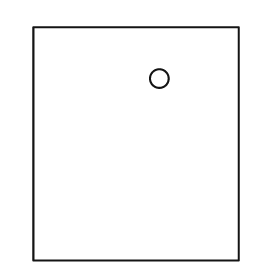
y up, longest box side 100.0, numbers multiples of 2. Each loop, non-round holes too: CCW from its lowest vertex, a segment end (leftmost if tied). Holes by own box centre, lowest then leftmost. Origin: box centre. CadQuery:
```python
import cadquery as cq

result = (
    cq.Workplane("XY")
    .moveTo(-44.0, -50.0)
    .lineTo(44.0, -50.0)
    .lineTo(44.0, 50.0)
    .lineTo(-44.0, 50.0)
    .close()
    .moveTo(10.0, 28.0)
    .circle(4.0)
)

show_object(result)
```